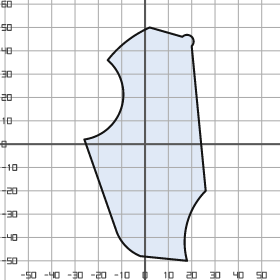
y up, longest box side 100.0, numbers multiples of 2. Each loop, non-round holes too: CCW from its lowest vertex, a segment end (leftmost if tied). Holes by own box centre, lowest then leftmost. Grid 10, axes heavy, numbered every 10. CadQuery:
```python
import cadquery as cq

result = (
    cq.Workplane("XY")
    .moveTo(18.0, -50.0)
    .threePointArc((18.0, -34.0), (26.0, -20.0))
    .lineTo(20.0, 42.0)
    .threePointArc((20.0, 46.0), (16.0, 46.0))
    .lineTo(2.0, 50.0)
    .threePointArc((-8.0, 44.0), (-16.0, 36.0))
    .threePointArc((-10.0, 16.0), (-26.0, 2.0))
    .lineTo(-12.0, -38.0)
    .threePointArc((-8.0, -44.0), (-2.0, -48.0))
    .close()
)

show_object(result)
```